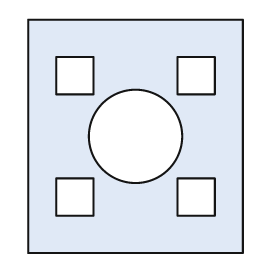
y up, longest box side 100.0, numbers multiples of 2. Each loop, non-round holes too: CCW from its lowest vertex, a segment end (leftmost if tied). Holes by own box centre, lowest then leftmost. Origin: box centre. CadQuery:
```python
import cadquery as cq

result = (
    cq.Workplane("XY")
    .moveTo(-46.0, -50.0)
    .lineTo(46.0, -50.0)
    .lineTo(46.0, 50.0)
    .lineTo(-46.0, 50.0)
    .close()
    .moveTo(-34.0, -34.0)
    .lineTo(-18.0, -34.0)
    .lineTo(-18.0, -18.0)
    .lineTo(-34.0, -18.0)
    .close()
    .moveTo(18.0, -34.0)
    .lineTo(34.0, -34.0)
    .lineTo(34.0, -18.0)
    .lineTo(18.0, -18.0)
    .close()
    .moveTo(0.0, 0.0)
    .circle(20.0)
    .moveTo(-34.0, 18.0)
    .lineTo(-18.0, 18.0)
    .lineTo(-18.0, 34.0)
    .lineTo(-34.0, 34.0)
    .close()
    .moveTo(18.0, 18.0)
    .lineTo(34.0, 18.0)
    .lineTo(34.0, 34.0)
    .lineTo(18.0, 34.0)
    .close()
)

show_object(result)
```